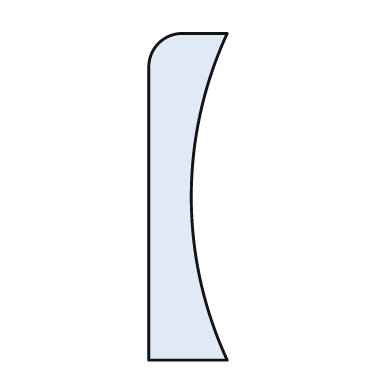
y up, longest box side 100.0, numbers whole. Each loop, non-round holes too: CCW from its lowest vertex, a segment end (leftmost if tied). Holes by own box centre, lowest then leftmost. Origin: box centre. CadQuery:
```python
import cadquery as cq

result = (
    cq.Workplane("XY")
    .moveTo(-12.0, -50.0)
    .lineTo(12.0, -50.0)
    .threePointArc((1.0, 0.0), (12.0, 50.0))
    .lineTo(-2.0, 50.0)
    .threePointArc((-9.0, 47.0), (-12.0, 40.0))
    .close()
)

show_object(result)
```